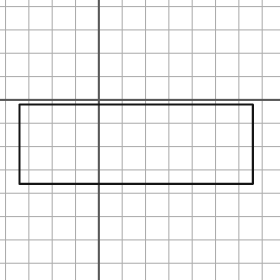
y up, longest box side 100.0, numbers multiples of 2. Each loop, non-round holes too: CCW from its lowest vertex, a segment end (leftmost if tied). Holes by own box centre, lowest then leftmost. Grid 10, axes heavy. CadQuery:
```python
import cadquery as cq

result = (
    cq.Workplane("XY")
    .moveTo(-34.0, -36.0)
    .lineTo(66.0, -36.0)
    .lineTo(66.0, -2.0)
    .lineTo(-34.0, -2.0)
    .close()
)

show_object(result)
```